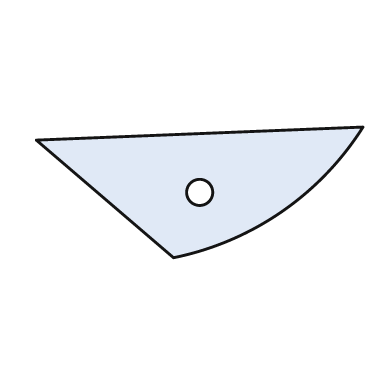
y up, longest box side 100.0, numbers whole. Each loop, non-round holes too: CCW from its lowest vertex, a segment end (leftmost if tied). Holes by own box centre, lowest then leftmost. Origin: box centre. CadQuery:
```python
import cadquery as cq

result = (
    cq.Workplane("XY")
    .moveTo(-8.0, -20.0)
    .threePointArc((25.0, -6.0), (50.0, 20.0))
    .lineTo(-50.0, 16.0)
    .close()
    .moveTo(0.0, 0.0)
    .circle(4.0)
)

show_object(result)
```